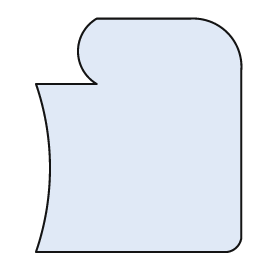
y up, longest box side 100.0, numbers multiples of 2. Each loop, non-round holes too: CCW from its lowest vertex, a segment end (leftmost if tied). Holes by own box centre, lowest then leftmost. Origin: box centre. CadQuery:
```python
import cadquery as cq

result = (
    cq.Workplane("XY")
    .moveTo(-44.0, -50.0)
    .lineTo(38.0, -50.0)
    .threePointArc((42.0, -48.0), (44.0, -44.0))
    .lineTo(44.0, 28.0)
    .threePointArc((38.0, 44.0), (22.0, 50.0))
    .lineTo(-18.0, 50.0)
    .threePointArc((-26.0, 36.0), (-18.0, 22.0))
    .lineTo(-44.0, 22.0)
    .threePointArc((-38.0, -14.0), (-44.0, -50.0))
    .close()
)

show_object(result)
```